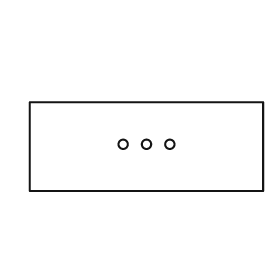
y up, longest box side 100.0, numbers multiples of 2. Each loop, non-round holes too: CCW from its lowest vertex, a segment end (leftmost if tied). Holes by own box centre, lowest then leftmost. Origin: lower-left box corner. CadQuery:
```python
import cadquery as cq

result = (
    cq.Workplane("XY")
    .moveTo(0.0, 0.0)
    .lineTo(100.0, 0.0)
    .lineTo(100.0, 38.0)
    .lineTo(0.0, 38.0)
    .close()
    .moveTo(40.0, 20.0)
    .circle(2.0)
    .moveTo(50.0, 20.0)
    .circle(2.0)
    .moveTo(60.0, 20.0)
    .circle(2.0)
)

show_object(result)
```